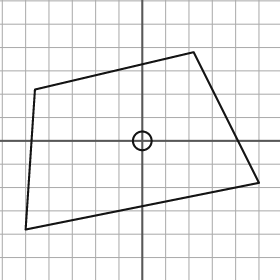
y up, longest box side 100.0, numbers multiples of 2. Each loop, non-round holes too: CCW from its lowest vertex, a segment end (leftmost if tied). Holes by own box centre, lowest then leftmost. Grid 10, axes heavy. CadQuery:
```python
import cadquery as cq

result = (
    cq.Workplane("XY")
    .moveTo(-50.0, -38.0)
    .lineTo(50.0, -18.0)
    .lineTo(22.0, 38.0)
    .lineTo(-46.0, 22.0)
    .close()
    .moveTo(0.0, 0.0)
    .circle(4.0)
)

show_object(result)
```